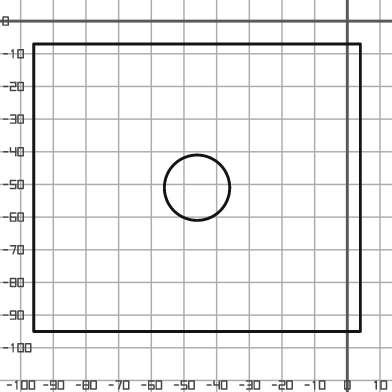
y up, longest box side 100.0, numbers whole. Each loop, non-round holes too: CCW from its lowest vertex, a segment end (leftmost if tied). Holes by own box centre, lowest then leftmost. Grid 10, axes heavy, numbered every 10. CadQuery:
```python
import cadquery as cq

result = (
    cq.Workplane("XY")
    .moveTo(-96.0, -95.0)
    .lineTo(4.0, -95.0)
    .lineTo(4.0, -7.0)
    .lineTo(-96.0, -7.0)
    .close()
    .moveTo(-46.0, -51.0)
    .circle(10.0)
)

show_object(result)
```